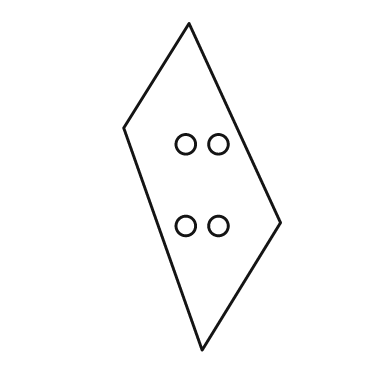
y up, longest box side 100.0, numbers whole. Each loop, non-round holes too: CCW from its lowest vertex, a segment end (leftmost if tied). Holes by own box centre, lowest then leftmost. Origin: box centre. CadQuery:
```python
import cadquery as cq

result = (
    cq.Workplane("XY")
    .moveTo(0.0, -50.0)
    .lineTo(24.0, -11.0)
    .lineTo(-4.0, 50.0)
    .lineTo(-24.0, 18.0)
    .close()
    .moveTo(-5.0, -12.0)
    .circle(3.0)
    .moveTo(5.0, -12.0)
    .circle(3.0)
    .moveTo(-5.0, 13.0)
    .circle(3.0)
    .moveTo(5.0, 13.0)
    .circle(3.0)
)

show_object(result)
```